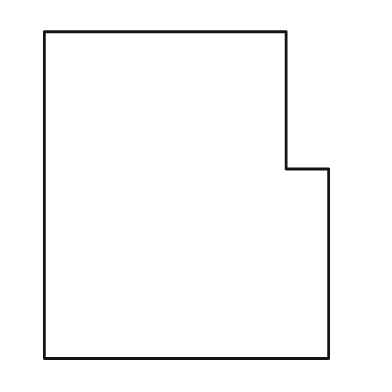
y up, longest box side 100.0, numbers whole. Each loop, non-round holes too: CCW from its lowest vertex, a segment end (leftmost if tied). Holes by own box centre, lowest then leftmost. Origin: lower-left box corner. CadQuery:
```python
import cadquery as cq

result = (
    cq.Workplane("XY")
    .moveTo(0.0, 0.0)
    .lineTo(87.0, 0.0)
    .lineTo(87.0, 58.0)
    .lineTo(74.0, 58.0)
    .lineTo(74.0, 100.0)
    .lineTo(0.0, 100.0)
    .close()
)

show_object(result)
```